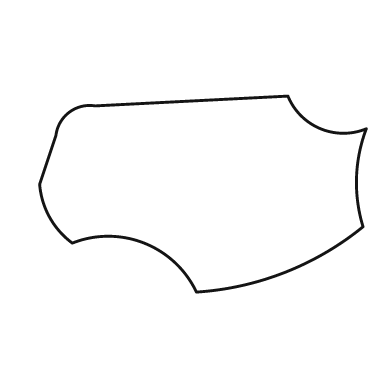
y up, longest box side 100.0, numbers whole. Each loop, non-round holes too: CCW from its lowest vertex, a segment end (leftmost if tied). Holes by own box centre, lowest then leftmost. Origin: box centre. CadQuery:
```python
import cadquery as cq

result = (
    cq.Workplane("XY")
    .moveTo(-2.0, -30.0)
    .threePointArc((25.0, -24.0), (49.0, -10.0))
    .threePointArc((47.0, 5.0), (50.0, 20.0))
    .threePointArc((36.0, 20.0), (26.0, 30.0))
    .lineTo(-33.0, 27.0)
    .threePointArc((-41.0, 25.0), (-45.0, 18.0))
    .lineTo(-50.0, 3.0)
    .threePointArc((-47.0, -7.0), (-40.0, -15.0))
    .threePointArc((-18.0, -15.0), (-2.0, -30.0))
    .close()
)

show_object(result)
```